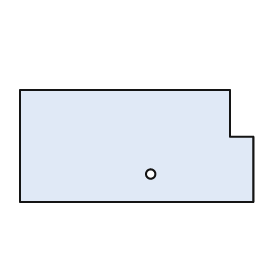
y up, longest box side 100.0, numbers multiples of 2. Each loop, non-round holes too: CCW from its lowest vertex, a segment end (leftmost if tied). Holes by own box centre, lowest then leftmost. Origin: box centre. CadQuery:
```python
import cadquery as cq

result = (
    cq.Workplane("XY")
    .moveTo(-50.0, -24.0)
    .lineTo(50.0, -24.0)
    .lineTo(50.0, 4.0)
    .lineTo(40.0, 4.0)
    .lineTo(40.0, 24.0)
    .lineTo(-50.0, 24.0)
    .close()
    .moveTo(6.0, -12.0)
    .circle(2.0)
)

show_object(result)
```